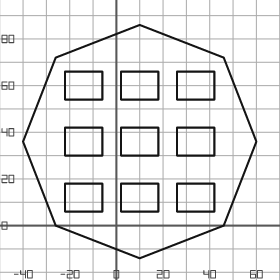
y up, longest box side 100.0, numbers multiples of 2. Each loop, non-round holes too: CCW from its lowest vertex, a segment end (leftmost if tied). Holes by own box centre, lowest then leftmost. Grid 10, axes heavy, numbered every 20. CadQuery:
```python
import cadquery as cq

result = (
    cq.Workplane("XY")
    .moveTo(10.0, -14.0)
    .lineTo(46.0, 0.0)
    .lineTo(60.0, 36.0)
    .lineTo(46.0, 72.0)
    .lineTo(10.0, 86.0)
    .lineTo(-26.0, 72.0)
    .lineTo(-40.0, 36.0)
    .lineTo(-26.0, 0.0)
    .close()
    .moveTo(-22.0, 6.0)
    .lineTo(-6.0, 6.0)
    .lineTo(-6.0, 18.0)
    .lineTo(-22.0, 18.0)
    .close()
    .moveTo(2.0, 6.0)
    .lineTo(18.0, 6.0)
    .lineTo(18.0, 18.0)
    .lineTo(2.0, 18.0)
    .close()
    .moveTo(26.0, 6.0)
    .lineTo(42.0, 6.0)
    .lineTo(42.0, 18.0)
    .lineTo(26.0, 18.0)
    .close()
    .moveTo(-22.0, 30.0)
    .lineTo(-6.0, 30.0)
    .lineTo(-6.0, 42.0)
    .lineTo(-22.0, 42.0)
    .close()
    .moveTo(2.0, 30.0)
    .lineTo(18.0, 30.0)
    .lineTo(18.0, 42.0)
    .lineTo(2.0, 42.0)
    .close()
    .moveTo(26.0, 30.0)
    .lineTo(42.0, 30.0)
    .lineTo(42.0, 42.0)
    .lineTo(26.0, 42.0)
    .close()
    .moveTo(-22.0, 54.0)
    .lineTo(-6.0, 54.0)
    .lineTo(-6.0, 66.0)
    .lineTo(-22.0, 66.0)
    .close()
    .moveTo(2.0, 54.0)
    .lineTo(18.0, 54.0)
    .lineTo(18.0, 66.0)
    .lineTo(2.0, 66.0)
    .close()
    .moveTo(26.0, 54.0)
    .lineTo(42.0, 54.0)
    .lineTo(42.0, 66.0)
    .lineTo(26.0, 66.0)
    .close()
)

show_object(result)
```